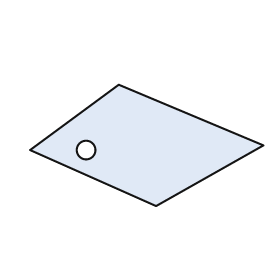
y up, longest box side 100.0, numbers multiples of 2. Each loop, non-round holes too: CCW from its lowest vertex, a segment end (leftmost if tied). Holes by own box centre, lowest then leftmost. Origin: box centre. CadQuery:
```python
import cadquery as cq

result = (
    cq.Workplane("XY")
    .moveTo(4.0, -26.0)
    .lineTo(50.0, 0.0)
    .lineTo(-12.0, 26.0)
    .lineTo(-50.0, -2.0)
    .close()
    .moveTo(-26.0, -2.0)
    .circle(4.0)
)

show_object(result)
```